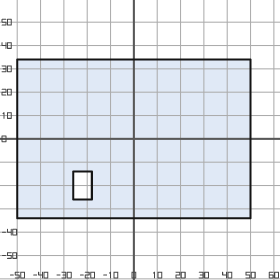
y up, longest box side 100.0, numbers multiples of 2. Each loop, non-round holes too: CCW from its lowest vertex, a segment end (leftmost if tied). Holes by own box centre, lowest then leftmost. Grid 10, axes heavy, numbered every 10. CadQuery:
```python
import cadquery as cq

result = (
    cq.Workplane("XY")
    .moveTo(-50.0, -34.0)
    .lineTo(50.0, -34.0)
    .lineTo(50.0, 34.0)
    .lineTo(-50.0, 34.0)
    .close()
    .moveTo(-26.0, -26.0)
    .lineTo(-18.0, -26.0)
    .lineTo(-18.0, -14.0)
    .lineTo(-26.0, -14.0)
    .close()
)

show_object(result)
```